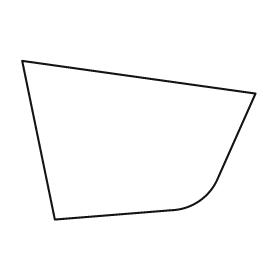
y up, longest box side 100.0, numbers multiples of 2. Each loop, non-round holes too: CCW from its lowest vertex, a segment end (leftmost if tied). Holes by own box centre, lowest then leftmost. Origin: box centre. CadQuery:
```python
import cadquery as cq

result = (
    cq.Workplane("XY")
    .moveTo(-36.0, -34.0)
    .lineTo(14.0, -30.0)
    .threePointArc((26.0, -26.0), (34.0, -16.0))
    .lineTo(50.0, 20.0)
    .lineTo(-50.0, 34.0)
    .close()
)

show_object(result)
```